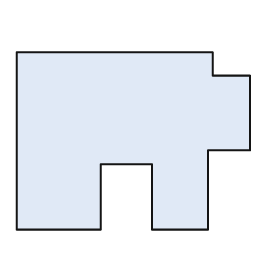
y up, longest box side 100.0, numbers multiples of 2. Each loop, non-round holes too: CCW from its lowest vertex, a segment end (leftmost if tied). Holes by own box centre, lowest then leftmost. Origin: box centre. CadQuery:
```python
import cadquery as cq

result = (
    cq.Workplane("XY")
    .moveTo(-50.0, -38.0)
    .lineTo(-14.0, -38.0)
    .lineTo(-14.0, -10.0)
    .lineTo(8.0, -10.0)
    .lineTo(8.0, -38.0)
    .lineTo(32.0, -38.0)
    .lineTo(32.0, -4.0)
    .lineTo(50.0, -4.0)
    .lineTo(50.0, 28.0)
    .lineTo(34.0, 28.0)
    .lineTo(34.0, 38.0)
    .lineTo(-50.0, 38.0)
    .close()
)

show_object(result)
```